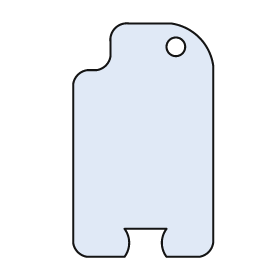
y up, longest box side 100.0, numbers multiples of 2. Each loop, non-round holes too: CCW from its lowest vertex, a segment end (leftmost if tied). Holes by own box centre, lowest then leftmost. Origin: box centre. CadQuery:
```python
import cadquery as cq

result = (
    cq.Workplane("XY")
    .moveTo(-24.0, -50.0)
    .lineTo(-8.0, -50.0)
    .threePointArc((-6.0, -44.0), (-8.0, -38.0))
    .lineTo(10.0, -38.0)
    .threePointArc((8.0, -44.0), (10.0, -50.0))
    .lineTo(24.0, -50.0)
    .threePointArc((28.0, -48.0), (30.0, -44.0))
    .lineTo(30.0, 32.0)
    .threePointArc((24.0, 44.0), (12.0, 50.0))
    .lineTo(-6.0, 50.0)
    .threePointArc((-12.0, 48.0), (-14.0, 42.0))
    .lineTo(-14.0, 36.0)
    .threePointArc((-16.0, 32.0), (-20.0, 30.0))
    .lineTo(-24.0, 30.0)
    .threePointArc((-28.0, 28.0), (-30.0, 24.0))
    .lineTo(-30.0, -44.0)
    .threePointArc((-28.0, -48.0), (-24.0, -50.0))
    .close()
    .moveTo(14.0, 40.0)
    .circle(4.0)
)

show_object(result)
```